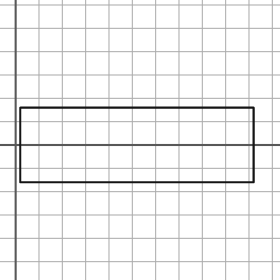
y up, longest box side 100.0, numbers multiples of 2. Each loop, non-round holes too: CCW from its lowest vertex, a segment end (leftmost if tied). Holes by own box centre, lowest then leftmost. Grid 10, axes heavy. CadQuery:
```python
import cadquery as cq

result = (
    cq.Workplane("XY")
    .moveTo(2.0, -16.0)
    .lineTo(102.0, -16.0)
    .lineTo(102.0, 16.0)
    .lineTo(2.0, 16.0)
    .close()
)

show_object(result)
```